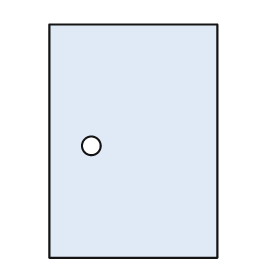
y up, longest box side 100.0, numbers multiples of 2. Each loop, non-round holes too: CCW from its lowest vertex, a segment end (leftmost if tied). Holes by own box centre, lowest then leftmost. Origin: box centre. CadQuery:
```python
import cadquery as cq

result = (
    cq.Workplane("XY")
    .moveTo(-36.0, -50.0)
    .lineTo(36.0, -50.0)
    .lineTo(36.0, 50.0)
    .lineTo(-36.0, 50.0)
    .close()
    .moveTo(-18.0, -2.0)
    .circle(4.0)
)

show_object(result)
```